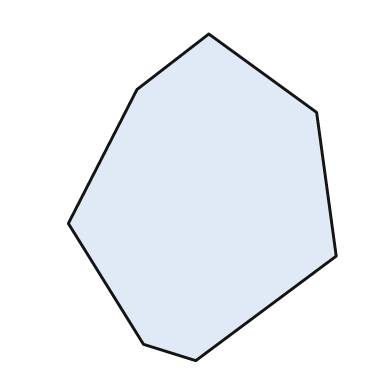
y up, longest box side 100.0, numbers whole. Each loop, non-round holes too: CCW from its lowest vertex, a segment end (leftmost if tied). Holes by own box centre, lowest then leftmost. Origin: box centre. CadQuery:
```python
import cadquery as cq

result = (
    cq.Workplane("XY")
    .moveTo(-2.0, -50.0)
    .lineTo(41.0, -18.0)
    .lineTo(35.0, 26.0)
    .lineTo(2.0, 50.0)
    .lineTo(-20.0, 33.0)
    .lineTo(-41.0, -8.0)
    .lineTo(-18.0, -45.0)
    .close()
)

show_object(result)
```